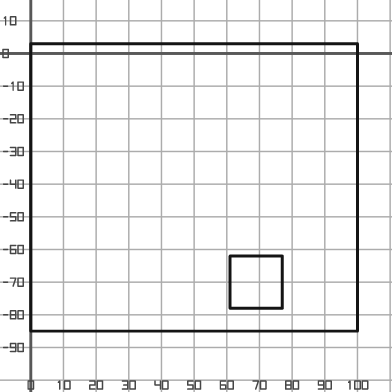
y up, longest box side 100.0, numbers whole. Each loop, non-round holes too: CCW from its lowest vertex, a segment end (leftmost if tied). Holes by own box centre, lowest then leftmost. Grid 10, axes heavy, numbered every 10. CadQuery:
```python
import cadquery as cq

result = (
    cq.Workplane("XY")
    .moveTo(0.0, -85.0)
    .lineTo(100.0, -85.0)
    .lineTo(100.0, 3.0)
    .lineTo(0.0, 3.0)
    .close()
    .moveTo(61.0, -78.0)
    .lineTo(77.0, -78.0)
    .lineTo(77.0, -62.0)
    .lineTo(61.0, -62.0)
    .close()
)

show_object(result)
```